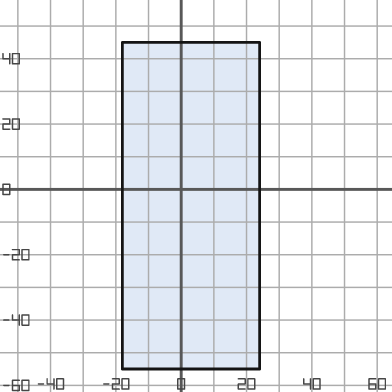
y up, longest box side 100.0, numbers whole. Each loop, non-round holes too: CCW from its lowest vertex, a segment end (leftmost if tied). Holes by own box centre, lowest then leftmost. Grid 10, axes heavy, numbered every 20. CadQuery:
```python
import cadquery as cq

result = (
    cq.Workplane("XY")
    .moveTo(-18.0, -55.0)
    .lineTo(24.0, -55.0)
    .lineTo(24.0, 45.0)
    .lineTo(-18.0, 45.0)
    .close()
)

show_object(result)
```